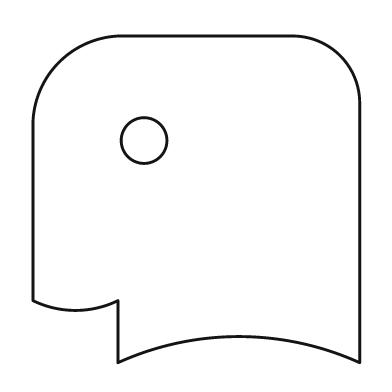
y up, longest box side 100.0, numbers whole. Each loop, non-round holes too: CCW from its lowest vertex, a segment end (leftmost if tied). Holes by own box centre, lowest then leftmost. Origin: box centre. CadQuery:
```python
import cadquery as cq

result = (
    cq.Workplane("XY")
    .moveTo(-24.0, -50.0)
    .threePointArc((13.0, -42.0), (50.0, -50.0))
    .lineTo(50.0, 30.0)
    .threePointArc((44.0, 44.0), (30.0, 50.0))
    .lineTo(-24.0, 50.0)
    .threePointArc((-42.0, 42.0), (-50.0, 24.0))
    .lineTo(-50.0, -31.0)
    .threePointArc((-37.0, -34.0), (-24.0, -31.0))
    .close()
    .moveTo(-16.0, 18.0)
    .circle(7.0)
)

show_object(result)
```